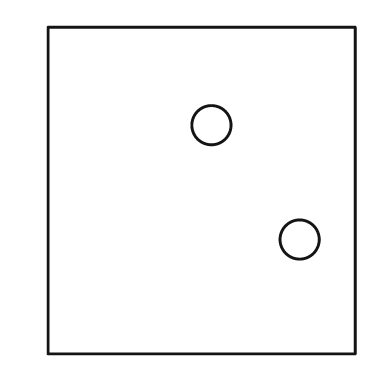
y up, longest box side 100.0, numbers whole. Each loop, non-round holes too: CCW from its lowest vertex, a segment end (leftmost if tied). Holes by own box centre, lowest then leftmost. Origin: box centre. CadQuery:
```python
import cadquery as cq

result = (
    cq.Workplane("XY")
    .moveTo(-47.0, -50.0)
    .lineTo(47.0, -50.0)
    .lineTo(47.0, 50.0)
    .lineTo(-47.0, 50.0)
    .close()
    .moveTo(30.0, -15.0)
    .circle(6.0)
    .moveTo(3.0, 20.0)
    .circle(6.0)
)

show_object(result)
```